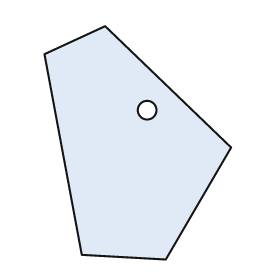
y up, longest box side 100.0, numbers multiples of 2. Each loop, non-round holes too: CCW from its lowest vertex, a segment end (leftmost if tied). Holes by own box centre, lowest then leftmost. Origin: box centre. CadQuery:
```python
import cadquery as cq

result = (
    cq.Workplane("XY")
    .moveTo(12.0, -50.0)
    .lineTo(40.0, -2.0)
    .lineTo(-14.0, 50.0)
    .lineTo(-40.0, 38.0)
    .lineTo(-24.0, -48.0)
    .close()
    .moveTo(4.0, 14.0)
    .circle(4.0)
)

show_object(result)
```